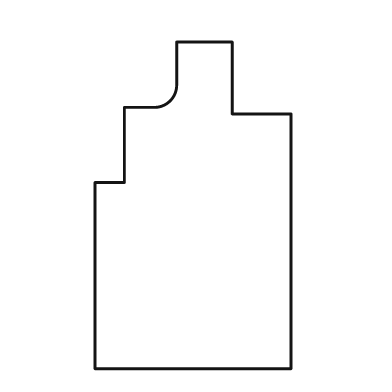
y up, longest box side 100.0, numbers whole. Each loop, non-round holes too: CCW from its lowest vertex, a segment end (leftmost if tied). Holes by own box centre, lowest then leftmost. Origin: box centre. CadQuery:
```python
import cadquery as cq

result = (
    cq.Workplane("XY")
    .moveTo(-30.0, -50.0)
    .lineTo(30.0, -50.0)
    .lineTo(30.0, 28.0)
    .lineTo(12.0, 28.0)
    .lineTo(12.0, 50.0)
    .lineTo(-5.0, 50.0)
    .lineTo(-5.0, 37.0)
    .threePointArc((-7.0, 32.0), (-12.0, 30.0))
    .lineTo(-21.0, 30.0)
    .lineTo(-21.0, 7.0)
    .lineTo(-30.0, 7.0)
    .close()
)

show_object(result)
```